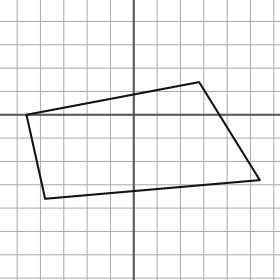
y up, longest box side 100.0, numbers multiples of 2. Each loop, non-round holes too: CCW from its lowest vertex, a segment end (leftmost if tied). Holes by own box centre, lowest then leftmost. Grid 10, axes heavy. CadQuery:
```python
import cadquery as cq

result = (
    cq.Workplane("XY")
    .moveTo(-38.0, -36.0)
    .lineTo(54.0, -28.0)
    .lineTo(28.0, 14.0)
    .lineTo(-46.0, 0.0)
    .close()
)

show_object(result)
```